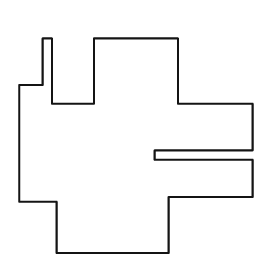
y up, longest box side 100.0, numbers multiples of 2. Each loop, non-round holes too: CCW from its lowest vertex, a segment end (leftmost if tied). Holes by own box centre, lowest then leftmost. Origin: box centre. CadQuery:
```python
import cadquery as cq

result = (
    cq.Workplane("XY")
    .moveTo(-34.0, -46.0)
    .lineTo(14.0, -46.0)
    .lineTo(14.0, -22.0)
    .lineTo(50.0, -22.0)
    .lineTo(50.0, -6.0)
    .lineTo(8.0, -6.0)
    .lineTo(8.0, -2.0)
    .lineTo(50.0, -2.0)
    .lineTo(50.0, 18.0)
    .lineTo(18.0, 18.0)
    .lineTo(18.0, 46.0)
    .lineTo(-18.0, 46.0)
    .lineTo(-18.0, 18.0)
    .lineTo(-36.0, 18.0)
    .lineTo(-36.0, 46.0)
    .lineTo(-40.0, 46.0)
    .lineTo(-40.0, 26.0)
    .lineTo(-50.0, 26.0)
    .lineTo(-50.0, -24.0)
    .lineTo(-34.0, -24.0)
    .close()
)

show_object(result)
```